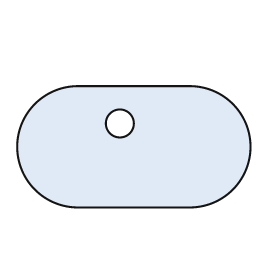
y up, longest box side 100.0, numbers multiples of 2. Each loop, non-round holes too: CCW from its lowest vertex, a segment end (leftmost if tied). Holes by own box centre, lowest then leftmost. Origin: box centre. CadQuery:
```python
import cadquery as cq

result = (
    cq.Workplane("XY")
    .moveTo(-24.0, -26.0)
    .lineTo(24.0, -26.0)
    .threePointArc((50.0, 0.0), (24.0, 26.0))
    .lineTo(-24.0, 26.0)
    .threePointArc((-50.0, 0.0), (-24.0, -26.0))
    .close()
    .moveTo(-6.0, 10.0)
    .circle(6.0)
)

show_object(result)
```